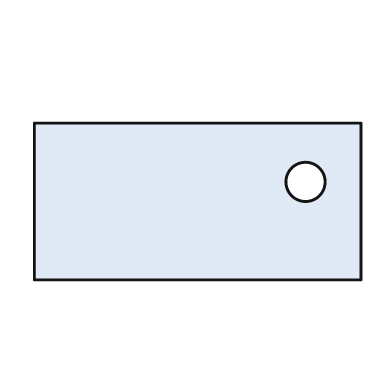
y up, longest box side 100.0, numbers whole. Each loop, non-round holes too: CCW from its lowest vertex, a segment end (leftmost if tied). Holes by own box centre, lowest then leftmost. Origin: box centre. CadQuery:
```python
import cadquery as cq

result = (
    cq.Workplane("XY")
    .moveTo(-50.0, -24.0)
    .lineTo(50.0, -24.0)
    .lineTo(50.0, 24.0)
    .lineTo(-50.0, 24.0)
    .close()
    .moveTo(33.0, 6.0)
    .circle(6.0)
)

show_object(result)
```